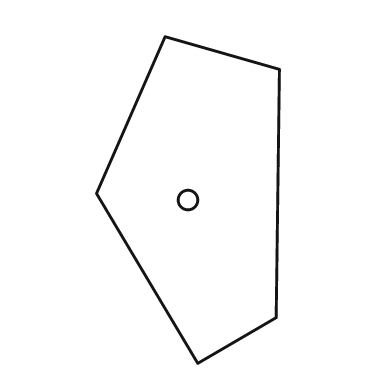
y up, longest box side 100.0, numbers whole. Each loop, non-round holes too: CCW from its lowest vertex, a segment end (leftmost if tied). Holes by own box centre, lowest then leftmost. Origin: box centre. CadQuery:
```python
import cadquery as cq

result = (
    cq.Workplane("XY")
    .moveTo(3.0, -50.0)
    .lineTo(27.0, -36.0)
    .lineTo(28.0, 40.0)
    .lineTo(-7.0, 50.0)
    .lineTo(-28.0, 2.0)
    .close()
    .moveTo(0.0, 0.0)
    .circle(3.0)
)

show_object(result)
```